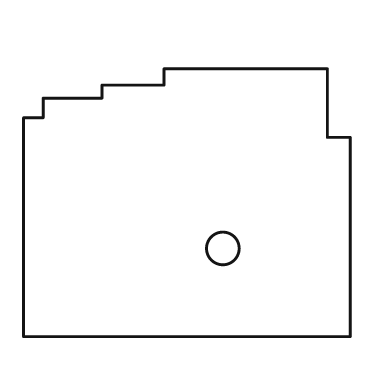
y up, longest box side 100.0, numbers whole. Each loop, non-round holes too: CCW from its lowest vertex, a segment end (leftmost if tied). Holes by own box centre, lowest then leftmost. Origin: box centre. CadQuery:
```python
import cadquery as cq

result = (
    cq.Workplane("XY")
    .moveTo(-50.0, -41.0)
    .lineTo(50.0, -41.0)
    .lineTo(50.0, 20.0)
    .lineTo(43.0, 20.0)
    .lineTo(43.0, 41.0)
    .lineTo(-7.0, 41.0)
    .lineTo(-7.0, 36.0)
    .lineTo(-26.0, 36.0)
    .lineTo(-26.0, 32.0)
    .lineTo(-44.0, 32.0)
    .lineTo(-44.0, 26.0)
    .lineTo(-50.0, 26.0)
    .close()
    .moveTo(11.0, -14.0)
    .circle(5.0)
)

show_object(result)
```